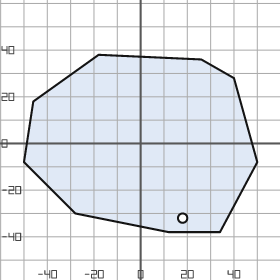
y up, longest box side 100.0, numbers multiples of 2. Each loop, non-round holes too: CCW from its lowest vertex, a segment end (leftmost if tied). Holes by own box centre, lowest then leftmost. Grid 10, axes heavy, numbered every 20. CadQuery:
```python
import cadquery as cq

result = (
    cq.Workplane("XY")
    .moveTo(12.0, -38.0)
    .lineTo(34.0, -38.0)
    .lineTo(50.0, -8.0)
    .lineTo(40.0, 28.0)
    .lineTo(26.0, 36.0)
    .lineTo(-18.0, 38.0)
    .lineTo(-46.0, 18.0)
    .lineTo(-50.0, -8.0)
    .lineTo(-28.0, -30.0)
    .close()
    .moveTo(18.0, -32.0)
    .circle(2.0)
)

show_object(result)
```